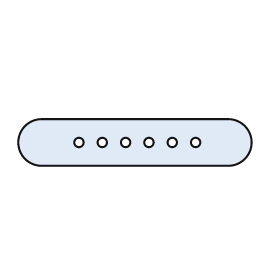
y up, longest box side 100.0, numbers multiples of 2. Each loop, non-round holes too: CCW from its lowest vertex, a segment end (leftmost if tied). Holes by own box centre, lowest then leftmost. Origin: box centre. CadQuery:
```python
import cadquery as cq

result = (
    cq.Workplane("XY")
    .moveTo(-40.0, -10.0)
    .lineTo(40.0, -10.0)
    .threePointArc((50.0, 0.0), (40.0, 10.0))
    .lineTo(-40.0, 10.0)
    .threePointArc((-50.0, 0.0), (-40.0, -10.0))
    .close()
    .moveTo(-24.0, 0.0)
    .circle(2.0)
    .moveTo(-14.0, 0.0)
    .circle(2.0)
    .moveTo(-4.0, 0.0)
    .circle(2.0)
    .moveTo(6.0, 0.0)
    .circle(2.0)
    .moveTo(16.0, 0.0)
    .circle(2.0)
    .moveTo(26.0, 0.0)
    .circle(2.0)
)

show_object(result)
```